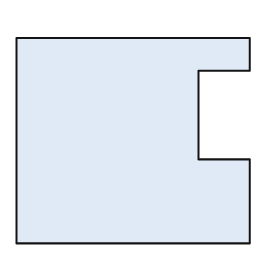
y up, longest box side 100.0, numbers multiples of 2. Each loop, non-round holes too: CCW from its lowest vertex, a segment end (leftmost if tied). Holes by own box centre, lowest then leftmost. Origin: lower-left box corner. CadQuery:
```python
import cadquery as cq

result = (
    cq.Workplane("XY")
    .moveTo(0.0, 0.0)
    .lineTo(100.0, 0.0)
    .lineTo(100.0, 36.0)
    .lineTo(78.0, 36.0)
    .lineTo(78.0, 74.0)
    .lineTo(100.0, 74.0)
    .lineTo(100.0, 88.0)
    .lineTo(0.0, 88.0)
    .close()
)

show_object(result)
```